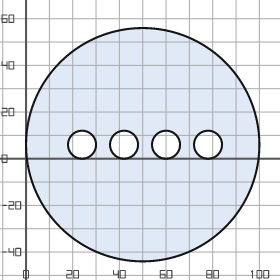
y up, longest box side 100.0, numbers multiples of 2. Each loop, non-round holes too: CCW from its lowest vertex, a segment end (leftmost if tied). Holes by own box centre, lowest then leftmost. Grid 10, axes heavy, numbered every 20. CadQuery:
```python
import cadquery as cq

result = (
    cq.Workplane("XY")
    .moveTo(50.0, 6.0)
    .circle(50.0)
    .moveTo(24.0, 6.0)
    .circle(6.0)
    .moveTo(42.0, 6.0)
    .circle(6.0)
    .moveTo(60.0, 6.0)
    .circle(6.0)
    .moveTo(78.0, 6.0)
    .circle(6.0)
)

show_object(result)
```